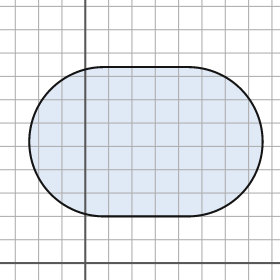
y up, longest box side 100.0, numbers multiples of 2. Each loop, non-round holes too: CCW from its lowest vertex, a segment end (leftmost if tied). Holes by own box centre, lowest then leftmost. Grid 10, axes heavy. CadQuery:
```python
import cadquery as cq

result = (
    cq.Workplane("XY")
    .moveTo(8.0, 20.0)
    .lineTo(44.0, 20.0)
    .threePointArc((76.0, 52.0), (44.0, 84.0))
    .lineTo(8.0, 84.0)
    .threePointArc((-24.0, 52.0), (8.0, 20.0))
    .close()
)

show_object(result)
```